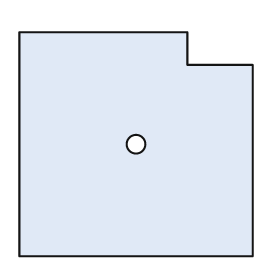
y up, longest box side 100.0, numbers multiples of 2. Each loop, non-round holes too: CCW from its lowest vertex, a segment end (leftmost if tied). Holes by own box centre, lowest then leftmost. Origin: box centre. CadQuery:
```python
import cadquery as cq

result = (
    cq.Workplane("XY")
    .moveTo(-50.0, -48.0)
    .lineTo(50.0, -48.0)
    .lineTo(50.0, 34.0)
    .lineTo(22.0, 34.0)
    .lineTo(22.0, 48.0)
    .lineTo(-50.0, 48.0)
    .close()
    .moveTo(0.0, 0.0)
    .circle(4.0)
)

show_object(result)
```